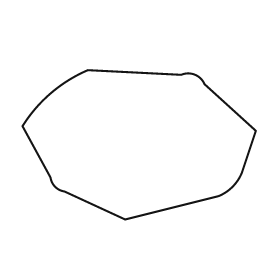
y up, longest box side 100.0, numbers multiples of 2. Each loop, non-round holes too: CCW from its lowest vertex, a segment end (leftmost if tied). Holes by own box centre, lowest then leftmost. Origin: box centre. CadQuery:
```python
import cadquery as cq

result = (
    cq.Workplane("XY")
    .moveTo(-6.0, -32.0)
    .lineTo(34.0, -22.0)
    .threePointArc((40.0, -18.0), (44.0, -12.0))
    .lineTo(50.0, 6.0)
    .lineTo(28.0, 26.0)
    .threePointArc((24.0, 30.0), (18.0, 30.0))
    .lineTo(-22.0, 32.0)
    .threePointArc((-38.0, 22.0), (-50.0, 8.0))
    .lineTo(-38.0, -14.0)
    .threePointArc((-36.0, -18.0), (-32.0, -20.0))
    .close()
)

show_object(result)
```